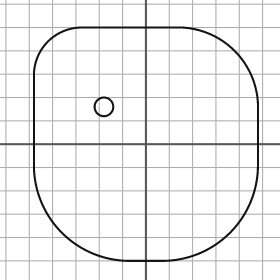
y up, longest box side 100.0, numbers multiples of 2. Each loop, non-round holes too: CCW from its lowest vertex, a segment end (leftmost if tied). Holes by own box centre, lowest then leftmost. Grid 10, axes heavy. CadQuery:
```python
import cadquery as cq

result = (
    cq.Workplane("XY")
    .moveTo(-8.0, -50.0)
    .lineTo(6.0, -50.0)
    .threePointArc((36.0, -38.0), (48.0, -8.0))
    .lineTo(48.0, 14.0)
    .threePointArc((38.0, 40.0), (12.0, 50.0))
    .lineTo(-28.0, 50.0)
    .threePointArc((-42.0, 44.0), (-48.0, 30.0))
    .lineTo(-48.0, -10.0)
    .threePointArc((-36.0, -38.0), (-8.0, -50.0))
    .close()
    .moveTo(-18.0, 16.0)
    .circle(4.0)
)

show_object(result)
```